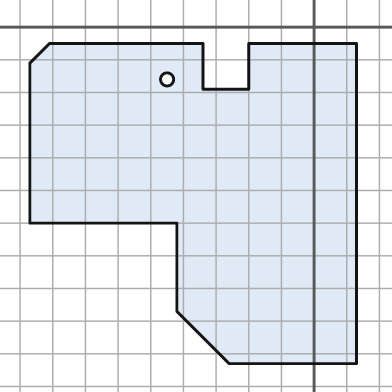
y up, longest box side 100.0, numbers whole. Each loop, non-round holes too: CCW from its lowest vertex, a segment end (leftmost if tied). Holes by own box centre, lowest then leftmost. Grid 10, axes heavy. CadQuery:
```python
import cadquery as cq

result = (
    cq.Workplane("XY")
    .moveTo(-26.0, -103.0)
    .lineTo(13.0, -103.0)
    .lineTo(13.0, -5.0)
    .lineTo(-20.0, -5.0)
    .lineTo(-20.0, -19.0)
    .lineTo(-34.0, -19.0)
    .lineTo(-34.0, -5.0)
    .lineTo(-81.0, -5.0)
    .lineTo(-87.0, -11.0)
    .lineTo(-87.0, -60.0)
    .lineTo(-42.0, -60.0)
    .lineTo(-42.0, -87.0)
    .close()
    .moveTo(-45.0, -16.0)
    .circle(2.0)
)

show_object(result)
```